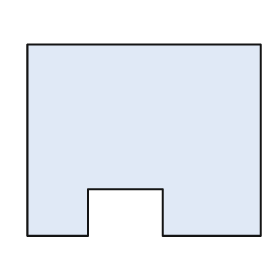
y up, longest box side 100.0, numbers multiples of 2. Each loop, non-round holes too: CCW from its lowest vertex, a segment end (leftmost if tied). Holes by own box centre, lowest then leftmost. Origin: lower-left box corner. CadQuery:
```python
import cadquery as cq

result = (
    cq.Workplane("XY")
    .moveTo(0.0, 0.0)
    .lineTo(26.0, 0.0)
    .lineTo(26.0, 20.0)
    .lineTo(58.0, 20.0)
    .lineTo(58.0, 0.0)
    .lineTo(100.0, 0.0)
    .lineTo(100.0, 82.0)
    .lineTo(0.0, 82.0)
    .close()
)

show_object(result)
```